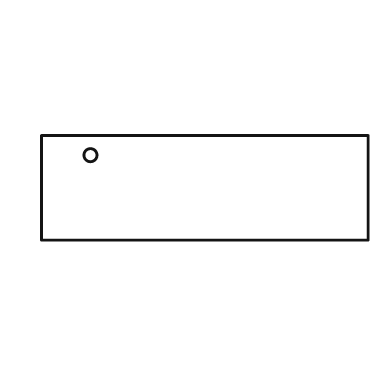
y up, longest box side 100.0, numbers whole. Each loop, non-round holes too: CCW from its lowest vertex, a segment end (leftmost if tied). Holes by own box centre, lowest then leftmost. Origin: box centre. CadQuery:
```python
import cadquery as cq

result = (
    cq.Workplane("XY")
    .moveTo(-50.0, -16.0)
    .lineTo(50.0, -16.0)
    .lineTo(50.0, 16.0)
    .lineTo(-50.0, 16.0)
    .close()
    .moveTo(-35.0, 10.0)
    .circle(2.0)
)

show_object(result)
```